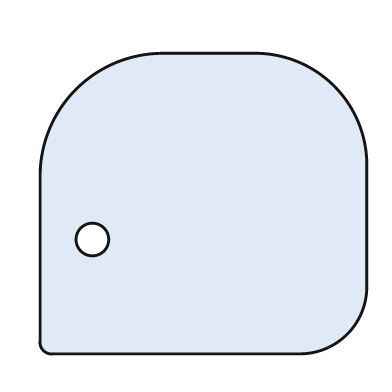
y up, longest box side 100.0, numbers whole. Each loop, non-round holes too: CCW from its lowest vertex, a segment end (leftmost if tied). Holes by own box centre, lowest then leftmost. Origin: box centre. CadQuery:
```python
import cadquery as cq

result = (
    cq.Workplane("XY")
    .moveTo(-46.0, -46.0)
    .lineTo(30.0, -46.0)
    .threePointArc((44.0, -40.0), (50.0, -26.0))
    .lineTo(50.0, 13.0)
    .threePointArc((40.0, 36.0), (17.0, 46.0))
    .lineTo(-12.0, 46.0)
    .threePointArc((-39.0, 35.0), (-50.0, 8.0))
    .lineTo(-50.0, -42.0)
    .threePointArc((-49.0, -45.0), (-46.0, -46.0))
    .close()
    .moveTo(-34.0, -11.0)
    .circle(5.0)
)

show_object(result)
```